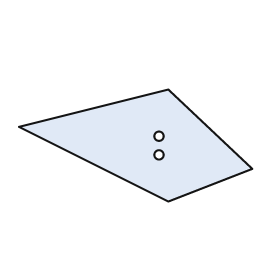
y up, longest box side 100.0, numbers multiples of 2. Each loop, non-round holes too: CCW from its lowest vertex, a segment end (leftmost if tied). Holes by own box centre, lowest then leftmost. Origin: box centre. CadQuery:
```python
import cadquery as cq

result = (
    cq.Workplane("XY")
    .moveTo(14.0, -24.0)
    .lineTo(50.0, -10.0)
    .lineTo(14.0, 24.0)
    .lineTo(-50.0, 8.0)
    .close()
    .moveTo(10.0, -4.0)
    .circle(2.0)
    .moveTo(10.0, 4.0)
    .circle(2.0)
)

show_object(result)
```